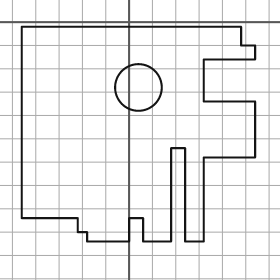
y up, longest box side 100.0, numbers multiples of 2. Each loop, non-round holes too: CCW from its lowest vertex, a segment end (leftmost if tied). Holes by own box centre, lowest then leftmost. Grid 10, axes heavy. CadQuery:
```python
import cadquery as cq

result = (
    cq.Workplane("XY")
    .moveTo(-18.0, -94.0)
    .lineTo(0.0, -94.0)
    .lineTo(0.0, -84.0)
    .lineTo(6.0, -84.0)
    .lineTo(6.0, -94.0)
    .lineTo(18.0, -94.0)
    .lineTo(18.0, -54.0)
    .lineTo(24.0, -54.0)
    .lineTo(24.0, -94.0)
    .lineTo(32.0, -94.0)
    .lineTo(32.0, -58.0)
    .lineTo(54.0, -58.0)
    .lineTo(54.0, -34.0)
    .lineTo(32.0, -34.0)
    .lineTo(32.0, -16.0)
    .lineTo(54.0, -16.0)
    .lineTo(54.0, -10.0)
    .lineTo(48.0, -10.0)
    .lineTo(48.0, -2.0)
    .lineTo(-46.0, -2.0)
    .lineTo(-46.0, -84.0)
    .lineTo(-22.0, -84.0)
    .lineTo(-22.0, -90.0)
    .lineTo(-18.0, -90.0)
    .close()
    .moveTo(4.0, -28.0)
    .circle(10.0)
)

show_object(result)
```